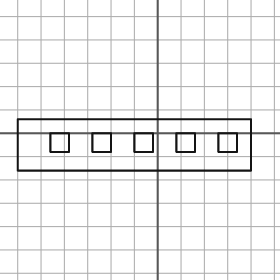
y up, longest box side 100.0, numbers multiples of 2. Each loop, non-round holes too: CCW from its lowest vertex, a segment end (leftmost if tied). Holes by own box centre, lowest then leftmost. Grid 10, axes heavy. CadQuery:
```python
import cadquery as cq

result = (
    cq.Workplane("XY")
    .moveTo(-60.0, -16.0)
    .lineTo(40.0, -16.0)
    .lineTo(40.0, 6.0)
    .lineTo(-60.0, 6.0)
    .close()
    .moveTo(-46.0, -8.0)
    .lineTo(-38.0, -8.0)
    .lineTo(-38.0, 0.0)
    .lineTo(-46.0, 0.0)
    .close()
    .moveTo(-28.0, -8.0)
    .lineTo(-20.0, -8.0)
    .lineTo(-20.0, 0.0)
    .lineTo(-28.0, 0.0)
    .close()
    .moveTo(-10.0, -8.0)
    .lineTo(-2.0, -8.0)
    .lineTo(-2.0, 0.0)
    .lineTo(-10.0, 0.0)
    .close()
    .moveTo(8.0, -8.0)
    .lineTo(16.0, -8.0)
    .lineTo(16.0, 0.0)
    .lineTo(8.0, 0.0)
    .close()
    .moveTo(26.0, -8.0)
    .lineTo(34.0, -8.0)
    .lineTo(34.0, 0.0)
    .lineTo(26.0, 0.0)
    .close()
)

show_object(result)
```